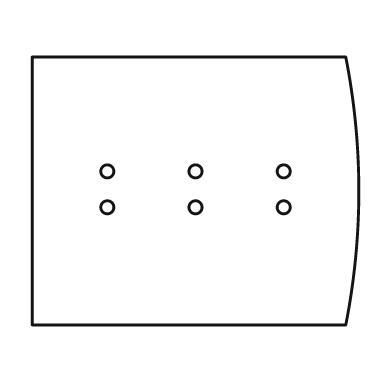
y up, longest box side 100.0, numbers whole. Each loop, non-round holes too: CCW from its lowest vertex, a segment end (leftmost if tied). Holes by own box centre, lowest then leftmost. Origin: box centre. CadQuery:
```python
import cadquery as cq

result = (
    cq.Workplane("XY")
    .moveTo(-50.0, -41.0)
    .lineTo(46.0, -41.0)
    .threePointArc((50.0, 0.0), (46.0, 41.0))
    .lineTo(-50.0, 41.0)
    .close()
    .moveTo(-27.0, -5.0)
    .circle(2.0)
    .moveTo(0.0, -5.0)
    .circle(2.0)
    .moveTo(27.0, -5.0)
    .circle(2.0)
    .moveTo(-27.0, 6.0)
    .circle(2.0)
    .moveTo(0.0, 6.0)
    .circle(2.0)
    .moveTo(27.0, 6.0)
    .circle(2.0)
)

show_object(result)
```